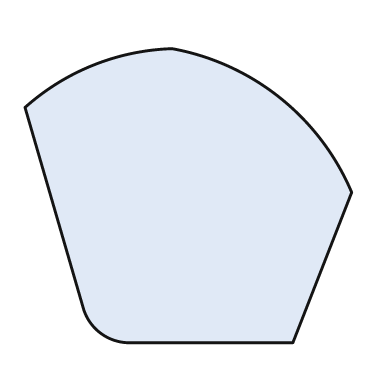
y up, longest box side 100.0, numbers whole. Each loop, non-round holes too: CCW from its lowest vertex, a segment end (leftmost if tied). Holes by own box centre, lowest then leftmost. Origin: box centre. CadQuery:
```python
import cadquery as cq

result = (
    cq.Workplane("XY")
    .moveTo(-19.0, -45.0)
    .lineTo(32.0, -45.0)
    .lineTo(50.0, 1.0)
    .threePointArc((28.0, 30.0), (-5.0, 45.0))
    .threePointArc((-29.0, 40.0), (-50.0, 27.0))
    .lineTo(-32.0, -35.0)
    .threePointArc((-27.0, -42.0), (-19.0, -45.0))
    .close()
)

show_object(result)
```